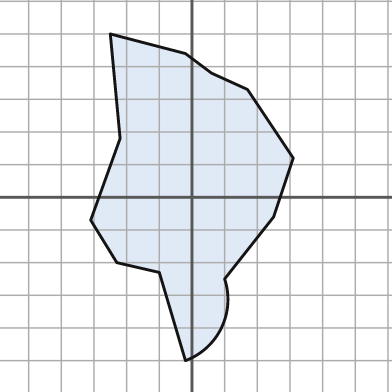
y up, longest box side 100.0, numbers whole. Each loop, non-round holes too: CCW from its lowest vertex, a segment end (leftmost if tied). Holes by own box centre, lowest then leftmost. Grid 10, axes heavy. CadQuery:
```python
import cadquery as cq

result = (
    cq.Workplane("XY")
    .moveTo(-2.0, -50.0)
    .threePointArc((9.0, -40.0), (10.0, -25.0))
    .lineTo(25.0, -6.0)
    .lineTo(31.0, 12.0)
    .lineTo(17.0, 33.0)
    .lineTo(6.0, 38.0)
    .lineTo(-2.0, 44.0)
    .lineTo(-25.0, 50.0)
    .lineTo(-22.0, 18.0)
    .lineTo(-31.0, -7.0)
    .lineTo(-23.0, -20.0)
    .lineTo(-10.0, -23.0)
    .close()
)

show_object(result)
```